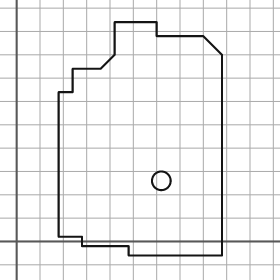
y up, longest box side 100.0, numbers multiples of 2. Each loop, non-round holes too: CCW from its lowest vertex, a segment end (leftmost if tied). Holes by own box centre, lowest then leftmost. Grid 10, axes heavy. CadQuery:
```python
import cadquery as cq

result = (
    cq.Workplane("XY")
    .moveTo(48.0, -6.0)
    .lineTo(88.0, -6.0)
    .lineTo(88.0, 80.0)
    .lineTo(80.0, 88.0)
    .lineTo(60.0, 88.0)
    .lineTo(60.0, 94.0)
    .lineTo(42.0, 94.0)
    .lineTo(42.0, 80.0)
    .lineTo(36.0, 74.0)
    .lineTo(24.0, 74.0)
    .lineTo(24.0, 64.0)
    .lineTo(18.0, 64.0)
    .lineTo(18.0, 2.0)
    .lineTo(28.0, 2.0)
    .lineTo(28.0, -2.0)
    .lineTo(48.0, -2.0)
    .close()
    .moveTo(62.0, 26.0)
    .circle(4.0)
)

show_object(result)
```